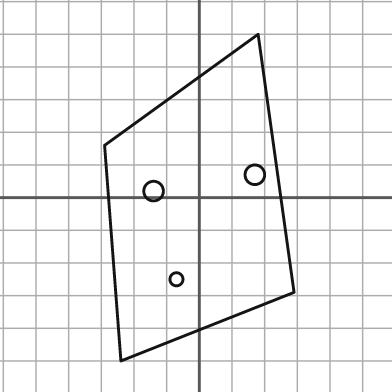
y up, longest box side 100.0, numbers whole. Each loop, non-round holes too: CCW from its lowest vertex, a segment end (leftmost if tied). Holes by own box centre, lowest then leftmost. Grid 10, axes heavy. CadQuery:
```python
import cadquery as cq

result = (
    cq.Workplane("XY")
    .moveTo(-24.0, -50.0)
    .lineTo(29.0, -29.0)
    .lineTo(18.0, 50.0)
    .lineTo(-29.0, 16.0)
    .close()
    .moveTo(-7.0, -25.0)
    .circle(2.0)
    .moveTo(-14.0, 2.0)
    .circle(3.0)
    .moveTo(17.0, 7.0)
    .circle(3.0)
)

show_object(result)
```